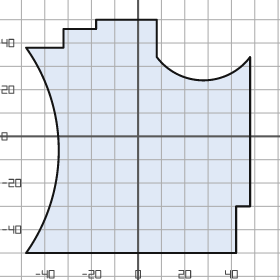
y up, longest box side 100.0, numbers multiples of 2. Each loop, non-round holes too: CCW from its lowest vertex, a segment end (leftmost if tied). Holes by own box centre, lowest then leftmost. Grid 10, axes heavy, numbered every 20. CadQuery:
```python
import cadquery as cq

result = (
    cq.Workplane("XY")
    .moveTo(-48.0, -50.0)
    .lineTo(42.0, -50.0)
    .lineTo(42.0, -30.0)
    .lineTo(48.0, -30.0)
    .lineTo(48.0, 34.0)
    .threePointArc((28.0, 24.0), (8.0, 34.0))
    .lineTo(8.0, 50.0)
    .lineTo(-18.0, 50.0)
    .lineTo(-18.0, 46.0)
    .lineTo(-32.0, 46.0)
    .lineTo(-32.0, 38.0)
    .lineTo(-48.0, 38.0)
    .threePointArc((-34.0, -6.0), (-48.0, -50.0))
    .close()
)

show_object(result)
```